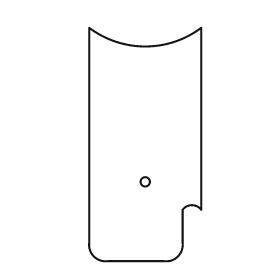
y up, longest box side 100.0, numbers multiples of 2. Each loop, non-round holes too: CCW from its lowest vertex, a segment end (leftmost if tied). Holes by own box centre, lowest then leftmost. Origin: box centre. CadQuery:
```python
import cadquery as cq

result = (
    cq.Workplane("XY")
    .moveTo(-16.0, -50.0)
    .lineTo(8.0, -50.0)
    .threePointArc((14.0, -48.0), (16.0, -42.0))
    .lineTo(16.0, -28.0)
    .threePointArc((20.0, -26.0), (24.0, -28.0))
    .lineTo(24.0, 50.0)
    .threePointArc((0.0, 42.0), (-24.0, 50.0))
    .lineTo(-24.0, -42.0)
    .threePointArc((-22.0, -48.0), (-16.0, -50.0))
    .close()
    .moveTo(0.0, -16.0)
    .circle(2.0)
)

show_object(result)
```